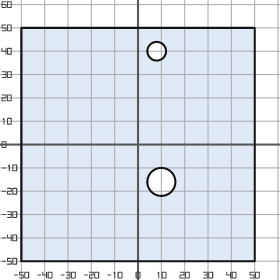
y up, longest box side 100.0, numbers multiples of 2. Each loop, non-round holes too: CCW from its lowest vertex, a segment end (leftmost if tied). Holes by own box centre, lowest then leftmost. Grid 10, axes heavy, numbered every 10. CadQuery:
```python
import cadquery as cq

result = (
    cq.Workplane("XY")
    .moveTo(-50.0, -50.0)
    .lineTo(50.0, -50.0)
    .lineTo(50.0, 50.0)
    .lineTo(-50.0, 50.0)
    .close()
    .moveTo(10.0, -16.0)
    .circle(6.0)
    .moveTo(8.0, 40.0)
    .circle(4.0)
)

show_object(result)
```